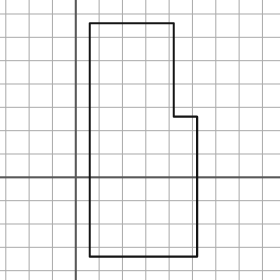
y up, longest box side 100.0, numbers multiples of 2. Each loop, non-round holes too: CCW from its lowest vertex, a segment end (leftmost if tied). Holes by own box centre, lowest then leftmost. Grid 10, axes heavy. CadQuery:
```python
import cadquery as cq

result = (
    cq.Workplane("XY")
    .moveTo(6.0, -34.0)
    .lineTo(52.0, -34.0)
    .lineTo(52.0, 26.0)
    .lineTo(42.0, 26.0)
    .lineTo(42.0, 66.0)
    .lineTo(6.0, 66.0)
    .close()
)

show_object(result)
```